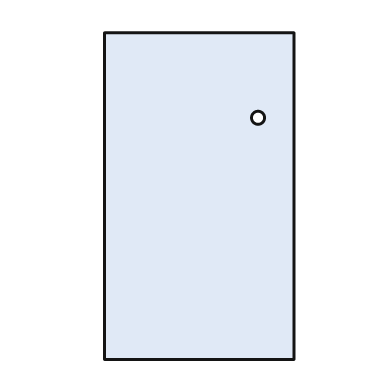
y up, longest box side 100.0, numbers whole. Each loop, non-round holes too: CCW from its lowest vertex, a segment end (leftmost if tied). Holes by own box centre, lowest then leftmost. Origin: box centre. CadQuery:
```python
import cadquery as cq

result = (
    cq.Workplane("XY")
    .moveTo(-29.0, -50.0)
    .lineTo(29.0, -50.0)
    .lineTo(29.0, 50.0)
    .lineTo(-29.0, 50.0)
    .close()
    .moveTo(18.0, 24.0)
    .circle(2.0)
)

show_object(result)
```